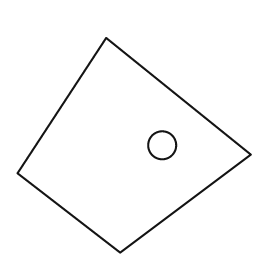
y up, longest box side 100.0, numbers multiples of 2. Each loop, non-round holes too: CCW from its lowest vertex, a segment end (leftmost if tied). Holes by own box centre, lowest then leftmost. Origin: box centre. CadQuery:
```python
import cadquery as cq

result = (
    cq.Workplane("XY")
    .moveTo(-6.0, -46.0)
    .lineTo(50.0, -4.0)
    .lineTo(-12.0, 46.0)
    .lineTo(-50.0, -12.0)
    .close()
    .moveTo(12.0, 0.0)
    .circle(6.0)
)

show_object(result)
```